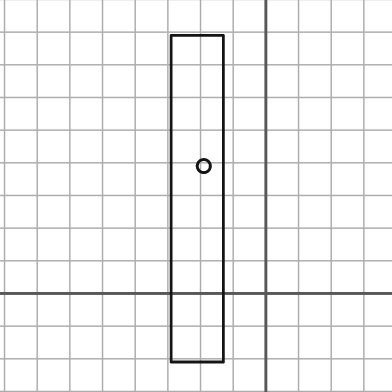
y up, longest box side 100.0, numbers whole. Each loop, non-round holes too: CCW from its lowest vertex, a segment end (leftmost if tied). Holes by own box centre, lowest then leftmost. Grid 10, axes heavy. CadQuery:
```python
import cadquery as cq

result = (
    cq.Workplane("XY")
    .moveTo(-29.0, -21.0)
    .lineTo(-13.0, -21.0)
    .lineTo(-13.0, 79.0)
    .lineTo(-29.0, 79.0)
    .close()
    .moveTo(-19.0, 39.0)
    .circle(2.0)
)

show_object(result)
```